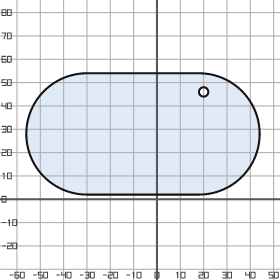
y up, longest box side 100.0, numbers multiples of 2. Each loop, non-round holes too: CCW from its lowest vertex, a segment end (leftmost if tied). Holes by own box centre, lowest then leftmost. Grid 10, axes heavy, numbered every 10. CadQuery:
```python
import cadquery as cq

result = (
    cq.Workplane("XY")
    .moveTo(-30.0, 2.0)
    .lineTo(18.0, 2.0)
    .threePointArc((44.0, 28.0), (18.0, 54.0))
    .lineTo(-30.0, 54.0)
    .threePointArc((-56.0, 28.0), (-30.0, 2.0))
    .close()
    .moveTo(20.0, 46.0)
    .circle(2.0)
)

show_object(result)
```